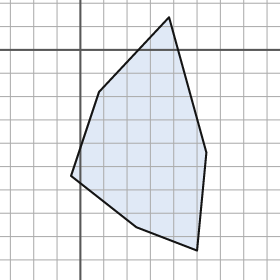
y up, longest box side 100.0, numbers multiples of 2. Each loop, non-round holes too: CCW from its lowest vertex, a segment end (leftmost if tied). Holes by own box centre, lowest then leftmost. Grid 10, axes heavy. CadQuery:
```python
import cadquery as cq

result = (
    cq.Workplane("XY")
    .moveTo(50.0, -86.0)
    .lineTo(54.0, -44.0)
    .lineTo(38.0, 14.0)
    .lineTo(8.0, -18.0)
    .lineTo(-4.0, -54.0)
    .lineTo(24.0, -76.0)
    .close()
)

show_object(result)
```